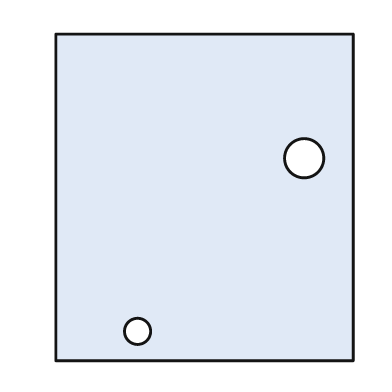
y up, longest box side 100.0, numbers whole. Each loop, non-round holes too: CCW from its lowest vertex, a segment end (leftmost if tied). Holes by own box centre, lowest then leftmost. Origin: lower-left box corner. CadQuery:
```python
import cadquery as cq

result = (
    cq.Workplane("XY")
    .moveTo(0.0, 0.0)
    .lineTo(91.0, 0.0)
    .lineTo(91.0, 100.0)
    .lineTo(0.0, 100.0)
    .close()
    .moveTo(25.0, 9.0)
    .circle(4.0)
    .moveTo(76.0, 62.0)
    .circle(6.0)
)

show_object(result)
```